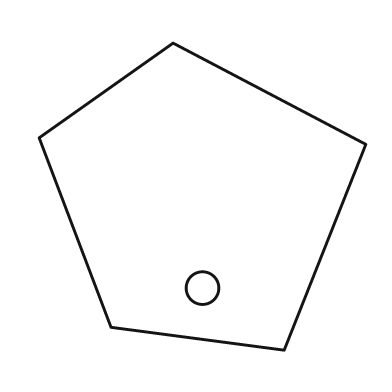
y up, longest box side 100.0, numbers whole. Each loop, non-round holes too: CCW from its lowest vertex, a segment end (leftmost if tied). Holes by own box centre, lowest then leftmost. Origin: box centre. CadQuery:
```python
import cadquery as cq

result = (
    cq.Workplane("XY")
    .moveTo(25.0, -47.0)
    .lineTo(50.0, 16.0)
    .lineTo(-9.0, 47.0)
    .lineTo(-50.0, 18.0)
    .lineTo(-28.0, -40.0)
    .close()
    .moveTo(0.0, -28.0)
    .circle(5.0)
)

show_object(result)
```